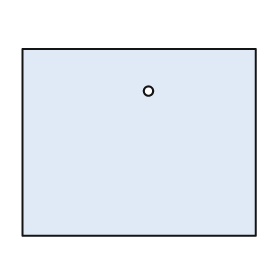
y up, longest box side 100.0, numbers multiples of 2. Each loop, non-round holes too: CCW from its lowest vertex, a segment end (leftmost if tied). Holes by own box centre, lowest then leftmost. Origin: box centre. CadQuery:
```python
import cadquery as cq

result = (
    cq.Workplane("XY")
    .moveTo(-50.0, -40.0)
    .lineTo(50.0, -40.0)
    .lineTo(50.0, 40.0)
    .lineTo(-50.0, 40.0)
    .close()
    .moveTo(4.0, 22.0)
    .circle(2.0)
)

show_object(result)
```